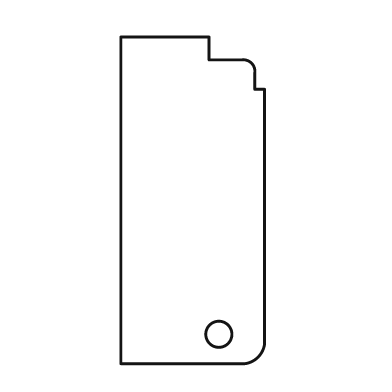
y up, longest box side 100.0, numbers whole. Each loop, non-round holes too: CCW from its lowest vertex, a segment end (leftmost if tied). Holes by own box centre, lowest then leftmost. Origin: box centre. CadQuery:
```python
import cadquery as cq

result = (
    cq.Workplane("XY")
    .moveTo(-22.0, -50.0)
    .lineTo(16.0, -50.0)
    .threePointArc((20.0, -48.0), (22.0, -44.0))
    .lineTo(22.0, 34.0)
    .lineTo(19.0, 34.0)
    .lineTo(19.0, 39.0)
    .threePointArc((18.0, 42.0), (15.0, 43.0))
    .lineTo(5.0, 43.0)
    .lineTo(5.0, 50.0)
    .lineTo(-22.0, 50.0)
    .close()
    .moveTo(8.0, -41.0)
    .circle(4.0)
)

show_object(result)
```